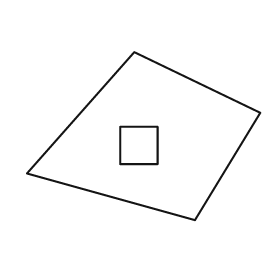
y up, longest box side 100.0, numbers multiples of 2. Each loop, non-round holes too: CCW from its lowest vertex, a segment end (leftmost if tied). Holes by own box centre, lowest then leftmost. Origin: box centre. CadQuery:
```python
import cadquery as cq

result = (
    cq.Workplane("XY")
    .moveTo(22.0, -36.0)
    .lineTo(50.0, 10.0)
    .lineTo(-4.0, 36.0)
    .lineTo(-50.0, -16.0)
    .close()
    .moveTo(-10.0, -12.0)
    .lineTo(6.0, -12.0)
    .lineTo(6.0, 4.0)
    .lineTo(-10.0, 4.0)
    .close()
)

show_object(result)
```